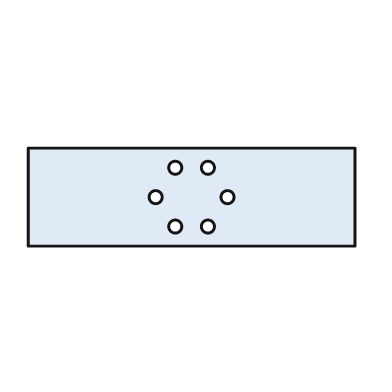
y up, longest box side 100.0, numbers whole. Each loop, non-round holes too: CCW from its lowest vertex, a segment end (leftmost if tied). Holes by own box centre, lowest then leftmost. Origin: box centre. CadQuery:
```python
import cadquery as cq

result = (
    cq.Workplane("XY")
    .moveTo(-50.0, -15.0)
    .lineTo(50.0, -15.0)
    .lineTo(50.0, 15.0)
    .lineTo(-50.0, 15.0)
    .close()
    .moveTo(-5.0, -9.0)
    .circle(2.0)
    .moveTo(5.0, -9.0)
    .circle(2.0)
    .moveTo(-11.0, 0.0)
    .circle(2.0)
    .moveTo(11.0, 0.0)
    .circle(2.0)
    .moveTo(-5.0, 9.0)
    .circle(2.0)
    .moveTo(5.0, 9.0)
    .circle(2.0)
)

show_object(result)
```